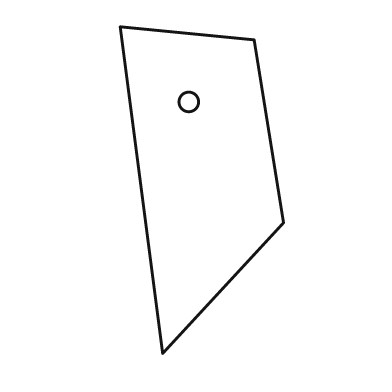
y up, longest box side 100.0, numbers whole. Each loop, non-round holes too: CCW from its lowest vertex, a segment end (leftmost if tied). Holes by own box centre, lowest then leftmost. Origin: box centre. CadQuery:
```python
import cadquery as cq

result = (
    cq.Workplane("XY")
    .moveTo(-12.0, -50.0)
    .lineTo(25.0, -10.0)
    .lineTo(16.0, 46.0)
    .lineTo(-25.0, 50.0)
    .close()
    .moveTo(-4.0, 27.0)
    .circle(3.0)
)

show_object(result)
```